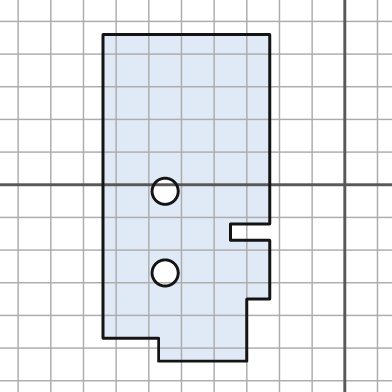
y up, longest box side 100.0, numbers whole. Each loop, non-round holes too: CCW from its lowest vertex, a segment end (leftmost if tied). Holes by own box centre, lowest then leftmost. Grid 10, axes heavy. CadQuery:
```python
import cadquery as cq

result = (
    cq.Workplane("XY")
    .moveTo(-57.0, -54.0)
    .lineTo(-30.0, -54.0)
    .lineTo(-30.0, -35.0)
    .lineTo(-23.0, -35.0)
    .lineTo(-23.0, -17.0)
    .lineTo(-35.0, -17.0)
    .lineTo(-35.0, -12.0)
    .lineTo(-23.0, -12.0)
    .lineTo(-23.0, 46.0)
    .lineTo(-74.0, 46.0)
    .lineTo(-74.0, -47.0)
    .lineTo(-57.0, -47.0)
    .close()
    .moveTo(-55.0, -27.0)
    .circle(4.0)
    .moveTo(-55.0, -2.0)
    .circle(4.0)
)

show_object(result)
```